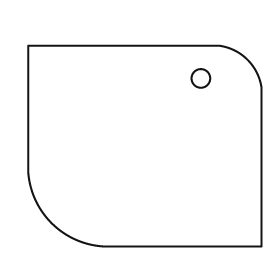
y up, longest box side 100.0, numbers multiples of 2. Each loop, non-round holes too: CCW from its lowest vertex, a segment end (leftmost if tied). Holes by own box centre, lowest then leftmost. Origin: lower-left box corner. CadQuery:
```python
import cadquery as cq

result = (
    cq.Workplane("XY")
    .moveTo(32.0, 0.0)
    .lineTo(100.0, 0.0)
    .lineTo(100.0, 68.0)
    .threePointArc((94.0, 80.0), (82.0, 86.0))
    .lineTo(0.0, 86.0)
    .lineTo(0.0, 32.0)
    .threePointArc((10.0, 10.0), (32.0, 0.0))
    .close()
    .moveTo(74.0, 72.0)
    .circle(4.0)
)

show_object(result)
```